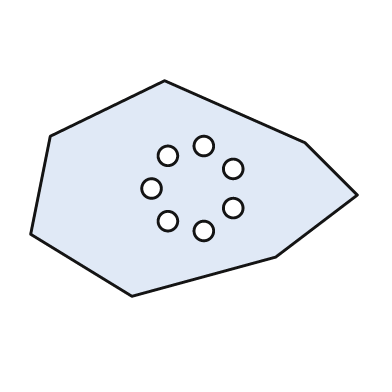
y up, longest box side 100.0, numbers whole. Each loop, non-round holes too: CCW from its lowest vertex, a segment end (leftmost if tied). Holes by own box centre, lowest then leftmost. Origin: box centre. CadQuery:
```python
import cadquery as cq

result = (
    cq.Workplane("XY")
    .moveTo(-19.0, -33.0)
    .lineTo(25.0, -21.0)
    .lineTo(50.0, -2.0)
    .lineTo(34.0, 14.0)
    .lineTo(-9.0, 33.0)
    .lineTo(-44.0, 16.0)
    .lineTo(-50.0, -14.0)
    .close()
    .moveTo(3.0, -13.0)
    .circle(3.0)
    .moveTo(-8.0, -10.0)
    .circle(3.0)
    .moveTo(12.0, -6.0)
    .circle(3.0)
    .moveTo(-13.0, 0.0)
    .circle(3.0)
    .moveTo(12.0, 6.0)
    .circle(3.0)
    .moveTo(-8.0, 10.0)
    .circle(3.0)
    .moveTo(3.0, 13.0)
    .circle(3.0)
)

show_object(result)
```